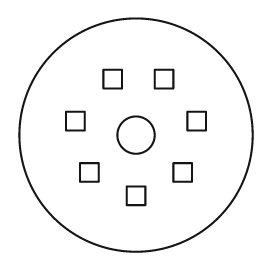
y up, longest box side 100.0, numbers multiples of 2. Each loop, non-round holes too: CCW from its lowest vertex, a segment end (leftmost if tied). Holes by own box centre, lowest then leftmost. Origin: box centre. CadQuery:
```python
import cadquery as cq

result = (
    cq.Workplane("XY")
    .moveTo(0.0, 0.0)
    .circle(50.0)
    .moveTo(-4.0, -30.0)
    .lineTo(4.0, -30.0)
    .lineTo(4.0, -22.0)
    .lineTo(-4.0, -22.0)
    .close()
    .moveTo(-24.0, -20.0)
    .lineTo(-16.0, -20.0)
    .lineTo(-16.0, -12.0)
    .lineTo(-24.0, -12.0)
    .close()
    .moveTo(16.0, -20.0)
    .lineTo(24.0, -20.0)
    .lineTo(24.0, -12.0)
    .lineTo(16.0, -12.0)
    .close()
    .moveTo(0.0, 0.0)
    .circle(8.0)
    .moveTo(-30.0, 2.0)
    .lineTo(-22.0, 2.0)
    .lineTo(-22.0, 10.0)
    .lineTo(-30.0, 10.0)
    .close()
    .moveTo(22.0, 2.0)
    .lineTo(30.0, 2.0)
    .lineTo(30.0, 10.0)
    .lineTo(22.0, 10.0)
    .close()
    .moveTo(-14.0, 20.0)
    .lineTo(-6.0, 20.0)
    .lineTo(-6.0, 28.0)
    .lineTo(-14.0, 28.0)
    .close()
    .moveTo(8.0, 20.0)
    .lineTo(16.0, 20.0)
    .lineTo(16.0, 28.0)
    .lineTo(8.0, 28.0)
    .close()
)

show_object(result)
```